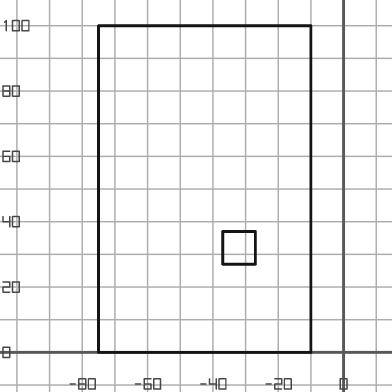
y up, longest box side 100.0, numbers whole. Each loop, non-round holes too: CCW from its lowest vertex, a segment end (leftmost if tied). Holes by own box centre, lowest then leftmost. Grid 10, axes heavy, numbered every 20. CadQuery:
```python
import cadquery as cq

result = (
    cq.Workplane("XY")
    .moveTo(-75.0, 0.0)
    .lineTo(-10.0, 0.0)
    .lineTo(-10.0, 100.0)
    .lineTo(-75.0, 100.0)
    .close()
    .moveTo(-37.0, 27.0)
    .lineTo(-27.0, 27.0)
    .lineTo(-27.0, 37.0)
    .lineTo(-37.0, 37.0)
    .close()
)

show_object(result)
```